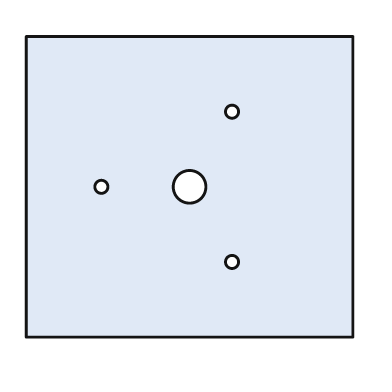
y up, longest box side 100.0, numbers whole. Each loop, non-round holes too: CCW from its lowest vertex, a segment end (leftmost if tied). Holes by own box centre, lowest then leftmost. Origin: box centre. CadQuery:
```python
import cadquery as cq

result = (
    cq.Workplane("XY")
    .moveTo(-50.0, -46.0)
    .lineTo(50.0, -46.0)
    .lineTo(50.0, 46.0)
    .lineTo(-50.0, 46.0)
    .close()
    .moveTo(13.0, -23.0)
    .circle(2.0)
    .moveTo(-27.0, 0.0)
    .circle(2.0)
    .moveTo(0.0, 0.0)
    .circle(5.0)
    .moveTo(13.0, 23.0)
    .circle(2.0)
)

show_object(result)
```